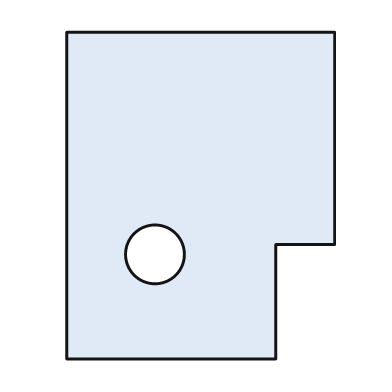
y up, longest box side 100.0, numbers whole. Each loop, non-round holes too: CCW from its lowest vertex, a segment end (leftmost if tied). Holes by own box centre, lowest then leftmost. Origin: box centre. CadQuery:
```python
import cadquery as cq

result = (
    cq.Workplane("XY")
    .moveTo(-41.0, -50.0)
    .lineTo(23.0, -50.0)
    .lineTo(23.0, -15.0)
    .lineTo(41.0, -15.0)
    .lineTo(41.0, 50.0)
    .lineTo(-41.0, 50.0)
    .close()
    .moveTo(-14.0, -18.0)
    .circle(9.0)
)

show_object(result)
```